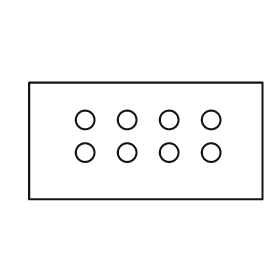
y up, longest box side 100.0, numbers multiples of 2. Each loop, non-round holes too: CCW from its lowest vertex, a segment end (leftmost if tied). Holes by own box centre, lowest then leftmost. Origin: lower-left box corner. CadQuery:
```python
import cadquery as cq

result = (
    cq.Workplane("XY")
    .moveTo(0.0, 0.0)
    .lineTo(100.0, 0.0)
    .lineTo(100.0, 50.0)
    .lineTo(0.0, 50.0)
    .close()
    .moveTo(24.0, 20.0)
    .circle(4.0)
    .moveTo(42.0, 20.0)
    .circle(4.0)
    .moveTo(60.0, 20.0)
    .circle(4.0)
    .moveTo(78.0, 20.0)
    .circle(4.0)
    .moveTo(24.0, 34.0)
    .circle(4.0)
    .moveTo(42.0, 34.0)
    .circle(4.0)
    .moveTo(60.0, 34.0)
    .circle(4.0)
    .moveTo(78.0, 34.0)
    .circle(4.0)
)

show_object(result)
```